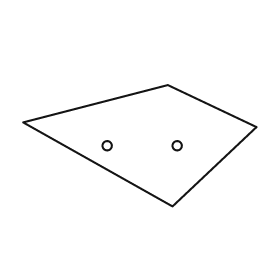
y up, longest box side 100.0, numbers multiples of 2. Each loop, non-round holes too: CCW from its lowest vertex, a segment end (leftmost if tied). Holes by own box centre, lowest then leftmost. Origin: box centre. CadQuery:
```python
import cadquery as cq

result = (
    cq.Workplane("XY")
    .moveTo(14.0, -26.0)
    .lineTo(50.0, 8.0)
    .lineTo(12.0, 26.0)
    .lineTo(-50.0, 10.0)
    .close()
    .moveTo(-14.0, 0.0)
    .circle(2.0)
    .moveTo(16.0, 0.0)
    .circle(2.0)
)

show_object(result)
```